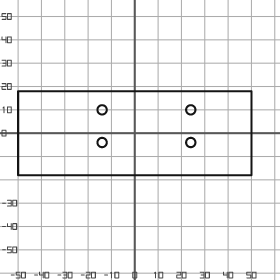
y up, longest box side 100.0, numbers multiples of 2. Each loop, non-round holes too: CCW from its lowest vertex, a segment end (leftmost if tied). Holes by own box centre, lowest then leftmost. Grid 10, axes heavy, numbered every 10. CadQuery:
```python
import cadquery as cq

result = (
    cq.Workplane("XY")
    .moveTo(-50.0, -18.0)
    .lineTo(50.0, -18.0)
    .lineTo(50.0, 18.0)
    .lineTo(-50.0, 18.0)
    .close()
    .moveTo(-14.0, -4.0)
    .circle(2.0)
    .moveTo(24.0, -4.0)
    .circle(2.0)
    .moveTo(-14.0, 10.0)
    .circle(2.0)
    .moveTo(24.0, 10.0)
    .circle(2.0)
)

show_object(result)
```